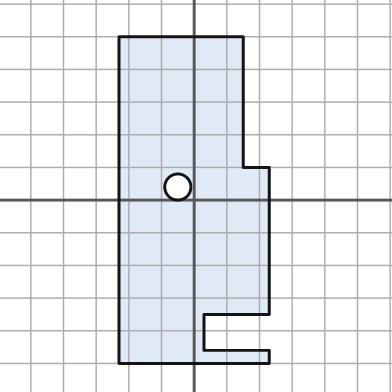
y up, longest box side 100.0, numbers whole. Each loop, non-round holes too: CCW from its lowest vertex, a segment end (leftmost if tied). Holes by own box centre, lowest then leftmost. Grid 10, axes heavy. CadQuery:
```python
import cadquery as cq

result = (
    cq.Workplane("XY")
    .moveTo(-23.0, -50.0)
    .lineTo(23.0, -50.0)
    .lineTo(23.0, -46.0)
    .lineTo(3.0, -46.0)
    .lineTo(3.0, -35.0)
    .lineTo(23.0, -35.0)
    .lineTo(23.0, 10.0)
    .lineTo(15.0, 10.0)
    .lineTo(15.0, 50.0)
    .lineTo(-23.0, 50.0)
    .close()
    .moveTo(-5.0, 4.0)
    .circle(4.0)
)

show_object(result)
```